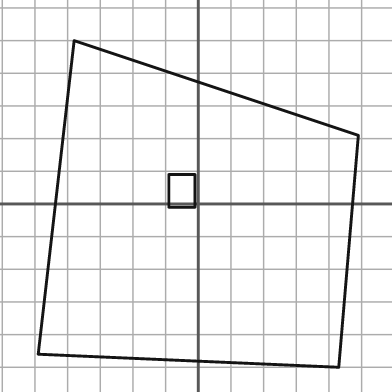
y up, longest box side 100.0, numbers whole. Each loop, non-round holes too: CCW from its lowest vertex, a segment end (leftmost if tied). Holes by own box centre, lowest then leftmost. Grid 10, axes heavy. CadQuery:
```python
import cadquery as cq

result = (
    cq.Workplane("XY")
    .moveTo(43.0, -50.0)
    .lineTo(49.0, 21.0)
    .lineTo(-38.0, 50.0)
    .lineTo(-49.0, -46.0)
    .close()
    .moveTo(-9.0, -1.0)
    .lineTo(-1.0, -1.0)
    .lineTo(-1.0, 9.0)
    .lineTo(-9.0, 9.0)
    .close()
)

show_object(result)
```